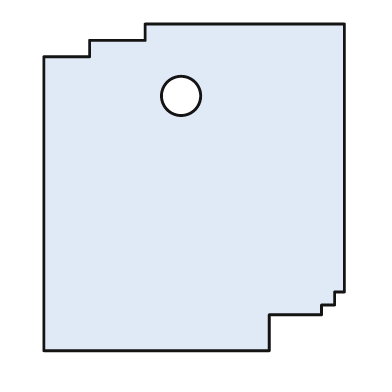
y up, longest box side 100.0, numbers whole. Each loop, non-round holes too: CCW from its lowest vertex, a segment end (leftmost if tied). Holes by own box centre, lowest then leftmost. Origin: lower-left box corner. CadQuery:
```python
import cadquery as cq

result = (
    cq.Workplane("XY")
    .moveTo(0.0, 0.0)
    .lineTo(69.0, 0.0)
    .lineTo(69.0, 11.0)
    .lineTo(85.0, 11.0)
    .lineTo(85.0, 14.0)
    .lineTo(89.0, 14.0)
    .lineTo(89.0, 18.0)
    .lineTo(92.0, 18.0)
    .lineTo(92.0, 100.0)
    .lineTo(31.0, 100.0)
    .lineTo(31.0, 95.0)
    .lineTo(14.0, 95.0)
    .lineTo(14.0, 90.0)
    .lineTo(0.0, 90.0)
    .close()
    .moveTo(42.0, 78.0)
    .circle(6.0)
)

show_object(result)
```